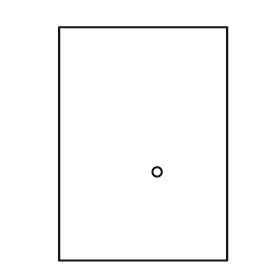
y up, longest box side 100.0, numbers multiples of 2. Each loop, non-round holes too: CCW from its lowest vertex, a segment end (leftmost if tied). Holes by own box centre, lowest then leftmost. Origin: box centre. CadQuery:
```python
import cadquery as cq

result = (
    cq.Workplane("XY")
    .moveTo(-36.0, -50.0)
    .lineTo(36.0, -50.0)
    .lineTo(36.0, 50.0)
    .lineTo(-36.0, 50.0)
    .close()
    .moveTo(6.0, -12.0)
    .circle(2.0)
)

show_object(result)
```